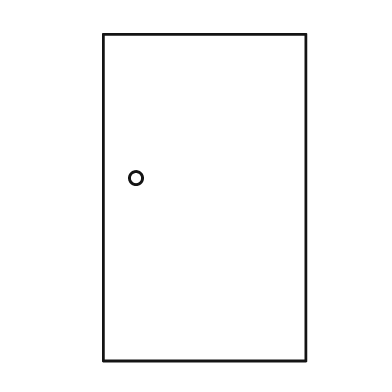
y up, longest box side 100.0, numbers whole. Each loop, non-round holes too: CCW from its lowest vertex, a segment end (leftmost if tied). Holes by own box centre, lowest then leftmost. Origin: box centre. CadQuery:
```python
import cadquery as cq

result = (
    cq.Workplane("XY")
    .moveTo(-31.0, -50.0)
    .lineTo(31.0, -50.0)
    .lineTo(31.0, 50.0)
    .lineTo(-31.0, 50.0)
    .close()
    .moveTo(-21.0, 6.0)
    .circle(2.0)
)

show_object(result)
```